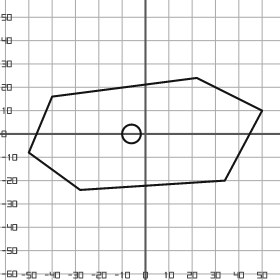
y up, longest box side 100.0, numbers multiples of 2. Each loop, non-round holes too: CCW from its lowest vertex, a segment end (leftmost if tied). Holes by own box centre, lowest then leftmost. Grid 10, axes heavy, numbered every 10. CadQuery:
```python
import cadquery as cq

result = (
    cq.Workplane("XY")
    .moveTo(-28.0, -24.0)
    .lineTo(34.0, -20.0)
    .lineTo(50.0, 10.0)
    .lineTo(22.0, 24.0)
    .lineTo(-40.0, 16.0)
    .lineTo(-50.0, -8.0)
    .close()
    .moveTo(-6.0, 0.0)
    .circle(4.0)
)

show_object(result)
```